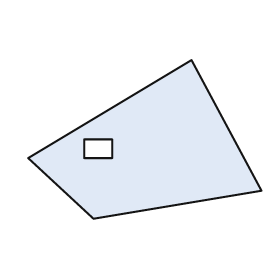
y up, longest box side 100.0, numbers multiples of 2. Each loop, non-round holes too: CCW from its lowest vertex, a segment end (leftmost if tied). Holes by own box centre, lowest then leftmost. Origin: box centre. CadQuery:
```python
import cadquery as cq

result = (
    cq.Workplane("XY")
    .moveTo(-22.0, -34.0)
    .lineTo(50.0, -22.0)
    .lineTo(20.0, 34.0)
    .lineTo(-50.0, -8.0)
    .close()
    .moveTo(-26.0, -8.0)
    .lineTo(-14.0, -8.0)
    .lineTo(-14.0, 0.0)
    .lineTo(-26.0, 0.0)
    .close()
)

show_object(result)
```